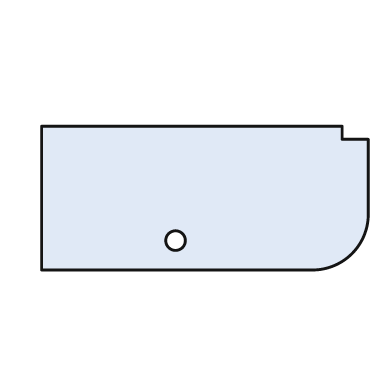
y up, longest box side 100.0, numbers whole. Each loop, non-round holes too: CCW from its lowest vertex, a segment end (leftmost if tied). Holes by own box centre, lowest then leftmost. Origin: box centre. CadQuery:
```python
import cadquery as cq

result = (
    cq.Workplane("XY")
    .moveTo(-50.0, -22.0)
    .lineTo(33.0, -22.0)
    .threePointArc((45.0, -17.0), (50.0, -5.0))
    .lineTo(50.0, 18.0)
    .lineTo(42.0, 18.0)
    .lineTo(42.0, 22.0)
    .lineTo(-50.0, 22.0)
    .close()
    .moveTo(-9.0, -13.0)
    .circle(3.0)
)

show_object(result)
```